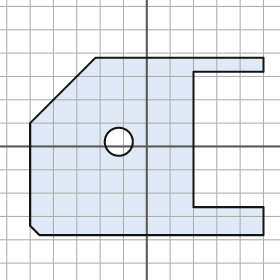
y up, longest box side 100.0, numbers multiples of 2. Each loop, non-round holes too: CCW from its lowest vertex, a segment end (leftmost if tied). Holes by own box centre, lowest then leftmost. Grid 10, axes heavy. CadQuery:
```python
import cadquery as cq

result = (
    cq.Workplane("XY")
    .moveTo(-46.0, -38.0)
    .lineTo(50.0, -38.0)
    .lineTo(50.0, -26.0)
    .lineTo(20.0, -26.0)
    .lineTo(20.0, 32.0)
    .lineTo(50.0, 32.0)
    .lineTo(50.0, 38.0)
    .lineTo(-22.0, 38.0)
    .lineTo(-50.0, 10.0)
    .lineTo(-50.0, -34.0)
    .close()
    .moveTo(-12.0, 2.0)
    .circle(6.0)
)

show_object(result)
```